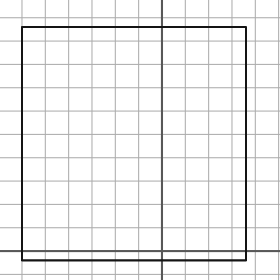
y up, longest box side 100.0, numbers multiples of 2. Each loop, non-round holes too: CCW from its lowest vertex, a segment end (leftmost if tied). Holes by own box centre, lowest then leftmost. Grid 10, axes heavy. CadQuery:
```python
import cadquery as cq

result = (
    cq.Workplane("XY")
    .moveTo(-60.0, -4.0)
    .lineTo(36.0, -4.0)
    .lineTo(36.0, 96.0)
    .lineTo(-60.0, 96.0)
    .close()
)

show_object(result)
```